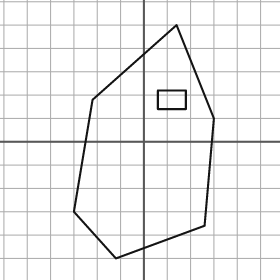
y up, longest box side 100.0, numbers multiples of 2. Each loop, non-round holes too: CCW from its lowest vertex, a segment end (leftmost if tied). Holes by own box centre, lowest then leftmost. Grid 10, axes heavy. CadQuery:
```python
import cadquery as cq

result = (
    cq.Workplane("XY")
    .moveTo(-12.0, -50.0)
    .lineTo(26.0, -36.0)
    .lineTo(30.0, 10.0)
    .lineTo(14.0, 50.0)
    .lineTo(-22.0, 18.0)
    .lineTo(-30.0, -30.0)
    .close()
    .moveTo(6.0, 14.0)
    .lineTo(18.0, 14.0)
    .lineTo(18.0, 22.0)
    .lineTo(6.0, 22.0)
    .close()
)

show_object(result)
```